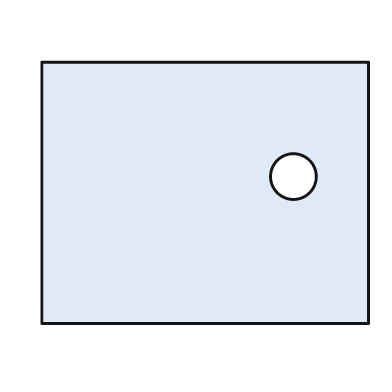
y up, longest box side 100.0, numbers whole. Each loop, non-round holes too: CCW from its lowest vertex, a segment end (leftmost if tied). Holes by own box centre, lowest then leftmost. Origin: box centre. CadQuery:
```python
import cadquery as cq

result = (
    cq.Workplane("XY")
    .moveTo(-50.0, -40.0)
    .lineTo(50.0, -40.0)
    .lineTo(50.0, 40.0)
    .lineTo(-50.0, 40.0)
    .close()
    .moveTo(27.0, 5.0)
    .circle(7.0)
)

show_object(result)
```